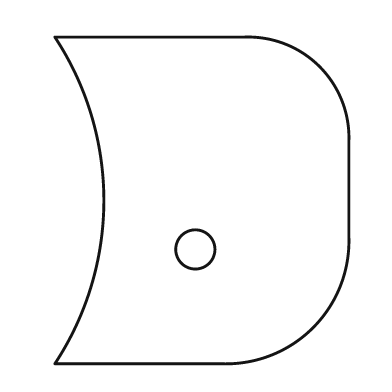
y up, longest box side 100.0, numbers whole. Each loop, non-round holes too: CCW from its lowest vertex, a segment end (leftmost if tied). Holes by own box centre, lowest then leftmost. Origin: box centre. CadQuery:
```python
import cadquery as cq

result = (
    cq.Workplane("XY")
    .moveTo(-45.0, -50.0)
    .lineTo(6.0, -50.0)
    .threePointArc((34.0, -39.0), (45.0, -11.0))
    .lineTo(45.0, 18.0)
    .threePointArc((36.0, 41.0), (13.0, 50.0))
    .lineTo(-45.0, 50.0)
    .threePointArc((-30.0, 0.0), (-45.0, -50.0))
    .close()
    .moveTo(-2.0, -15.0)
    .circle(6.0)
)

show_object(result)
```